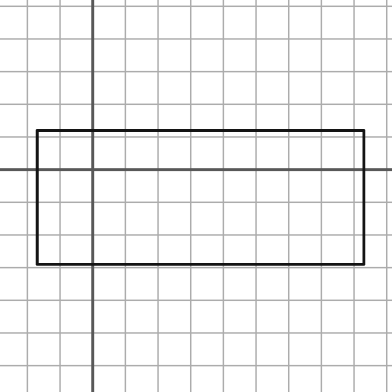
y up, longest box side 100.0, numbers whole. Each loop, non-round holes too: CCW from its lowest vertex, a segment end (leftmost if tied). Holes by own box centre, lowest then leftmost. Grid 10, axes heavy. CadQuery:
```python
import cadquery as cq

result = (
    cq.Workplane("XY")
    .moveTo(-17.0, -29.0)
    .lineTo(83.0, -29.0)
    .lineTo(83.0, 12.0)
    .lineTo(-17.0, 12.0)
    .close()
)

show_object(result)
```